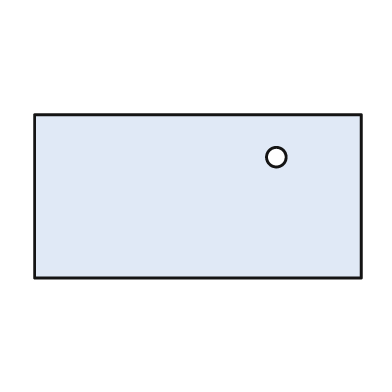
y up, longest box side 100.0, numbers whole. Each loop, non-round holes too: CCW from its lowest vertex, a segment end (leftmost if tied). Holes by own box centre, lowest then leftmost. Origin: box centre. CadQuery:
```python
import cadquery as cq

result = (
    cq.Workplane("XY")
    .moveTo(-50.0, -25.0)
    .lineTo(50.0, -25.0)
    .lineTo(50.0, 25.0)
    .lineTo(-50.0, 25.0)
    .close()
    .moveTo(24.0, 12.0)
    .circle(3.0)
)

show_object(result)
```